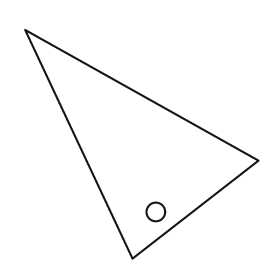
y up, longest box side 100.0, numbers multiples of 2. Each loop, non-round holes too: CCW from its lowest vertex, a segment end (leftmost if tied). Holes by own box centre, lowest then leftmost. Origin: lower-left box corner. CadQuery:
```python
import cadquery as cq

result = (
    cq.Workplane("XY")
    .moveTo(46.0, 0.0)
    .lineTo(100.0, 42.0)
    .lineTo(0.0, 98.0)
    .close()
    .moveTo(56.0, 20.0)
    .circle(4.0)
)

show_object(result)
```